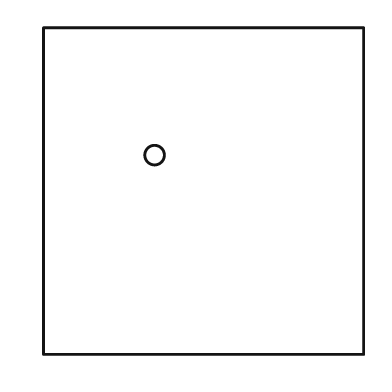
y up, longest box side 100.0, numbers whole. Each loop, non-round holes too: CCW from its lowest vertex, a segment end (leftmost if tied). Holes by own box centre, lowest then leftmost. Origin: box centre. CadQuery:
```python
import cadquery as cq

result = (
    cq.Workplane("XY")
    .moveTo(-49.0, -50.0)
    .lineTo(49.0, -50.0)
    .lineTo(49.0, 50.0)
    .lineTo(-49.0, 50.0)
    .close()
    .moveTo(-15.0, 11.0)
    .circle(3.0)
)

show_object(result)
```